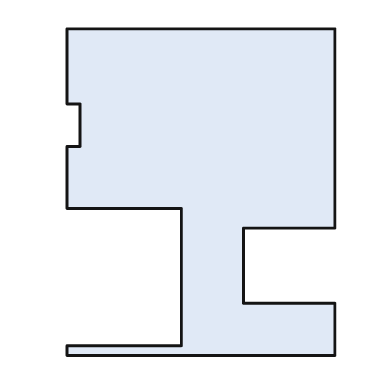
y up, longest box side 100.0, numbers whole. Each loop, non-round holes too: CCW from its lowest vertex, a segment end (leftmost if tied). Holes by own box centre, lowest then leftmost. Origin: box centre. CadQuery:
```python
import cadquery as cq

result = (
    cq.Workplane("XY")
    .moveTo(-41.0, -50.0)
    .lineTo(41.0, -50.0)
    .lineTo(41.0, -34.0)
    .lineTo(13.0, -34.0)
    .lineTo(13.0, -11.0)
    .lineTo(41.0, -11.0)
    .lineTo(41.0, 50.0)
    .lineTo(-41.0, 50.0)
    .lineTo(-41.0, 27.0)
    .lineTo(-37.0, 27.0)
    .lineTo(-37.0, 14.0)
    .lineTo(-41.0, 14.0)
    .lineTo(-41.0, -5.0)
    .lineTo(-6.0, -5.0)
    .lineTo(-6.0, -47.0)
    .lineTo(-41.0, -47.0)
    .close()
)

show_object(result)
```